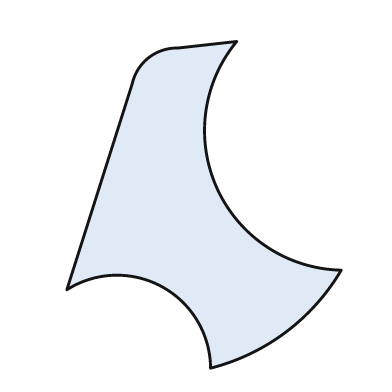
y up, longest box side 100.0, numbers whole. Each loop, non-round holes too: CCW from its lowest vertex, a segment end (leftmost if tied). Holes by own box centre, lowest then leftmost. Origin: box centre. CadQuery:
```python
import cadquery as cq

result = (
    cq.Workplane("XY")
    .moveTo(2.0, -50.0)
    .threePointArc((25.0, -39.0), (42.0, -20.0))
    .threePointArc((4.0, 5.0), (10.0, 50.0))
    .lineTo(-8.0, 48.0)
    .threePointArc((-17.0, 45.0), (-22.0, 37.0))
    .lineTo(-42.0, -26.0)
    .threePointArc((-13.0, -25.0), (2.0, -50.0))
    .close()
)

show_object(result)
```